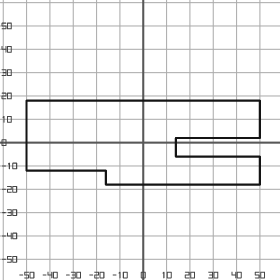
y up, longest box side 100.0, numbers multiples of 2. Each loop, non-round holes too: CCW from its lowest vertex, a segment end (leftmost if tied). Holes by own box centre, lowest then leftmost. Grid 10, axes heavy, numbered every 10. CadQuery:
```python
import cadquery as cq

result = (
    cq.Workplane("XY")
    .moveTo(-16.0, -18.0)
    .lineTo(50.0, -18.0)
    .lineTo(50.0, -6.0)
    .lineTo(14.0, -6.0)
    .lineTo(14.0, 2.0)
    .lineTo(50.0, 2.0)
    .lineTo(50.0, 18.0)
    .lineTo(-50.0, 18.0)
    .lineTo(-50.0, -12.0)
    .lineTo(-16.0, -12.0)
    .close()
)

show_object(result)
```